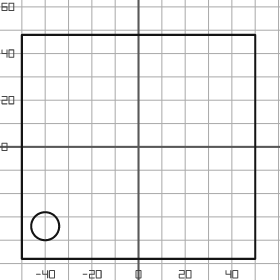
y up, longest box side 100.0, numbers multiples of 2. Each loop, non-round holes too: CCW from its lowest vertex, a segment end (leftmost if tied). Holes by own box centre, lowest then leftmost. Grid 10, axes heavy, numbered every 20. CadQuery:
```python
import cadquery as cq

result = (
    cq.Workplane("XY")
    .moveTo(-50.0, -48.0)
    .lineTo(50.0, -48.0)
    .lineTo(50.0, 48.0)
    .lineTo(-50.0, 48.0)
    .close()
    .moveTo(-40.0, -34.0)
    .circle(6.0)
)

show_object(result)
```